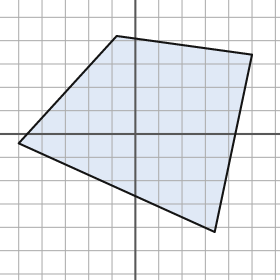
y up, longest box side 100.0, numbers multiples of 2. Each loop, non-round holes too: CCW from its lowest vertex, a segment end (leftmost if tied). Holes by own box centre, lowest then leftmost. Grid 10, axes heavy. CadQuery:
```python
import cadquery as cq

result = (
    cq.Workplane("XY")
    .moveTo(34.0, -42.0)
    .lineTo(50.0, 34.0)
    .lineTo(-8.0, 42.0)
    .lineTo(-50.0, -4.0)
    .close()
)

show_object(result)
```